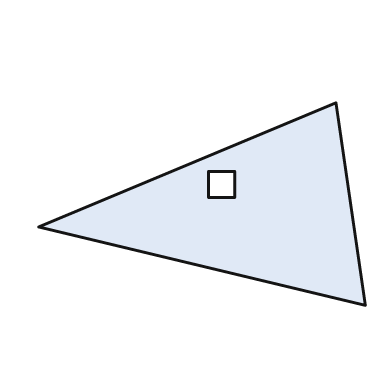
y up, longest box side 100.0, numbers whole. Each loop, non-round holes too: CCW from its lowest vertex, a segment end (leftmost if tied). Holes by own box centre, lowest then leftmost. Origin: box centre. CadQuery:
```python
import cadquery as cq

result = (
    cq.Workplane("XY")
    .moveTo(50.0, -31.0)
    .lineTo(41.0, 31.0)
    .lineTo(-50.0, -7.0)
    .close()
    .moveTo(2.0, 2.0)
    .lineTo(10.0, 2.0)
    .lineTo(10.0, 10.0)
    .lineTo(2.0, 10.0)
    .close()
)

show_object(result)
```